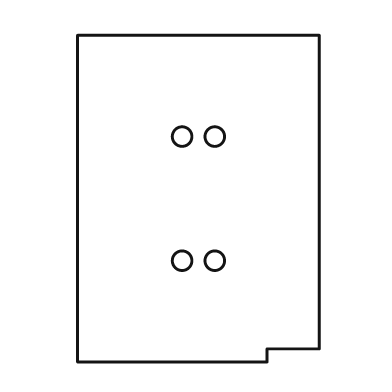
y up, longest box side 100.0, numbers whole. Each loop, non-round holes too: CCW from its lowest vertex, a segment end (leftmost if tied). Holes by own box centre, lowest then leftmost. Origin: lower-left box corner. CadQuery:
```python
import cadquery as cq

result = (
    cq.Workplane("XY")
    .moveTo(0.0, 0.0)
    .lineTo(58.0, 0.0)
    .lineTo(58.0, 4.0)
    .lineTo(74.0, 4.0)
    .lineTo(74.0, 100.0)
    .lineTo(0.0, 100.0)
    .close()
    .moveTo(32.0, 31.0)
    .circle(3.0)
    .moveTo(42.0, 31.0)
    .circle(3.0)
    .moveTo(32.0, 69.0)
    .circle(3.0)
    .moveTo(42.0, 69.0)
    .circle(3.0)
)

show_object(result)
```